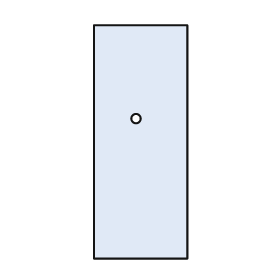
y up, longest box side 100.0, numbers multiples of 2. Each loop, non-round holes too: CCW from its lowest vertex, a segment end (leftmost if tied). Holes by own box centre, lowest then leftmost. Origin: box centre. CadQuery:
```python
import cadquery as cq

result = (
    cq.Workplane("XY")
    .moveTo(-20.0, -50.0)
    .lineTo(20.0, -50.0)
    .lineTo(20.0, 50.0)
    .lineTo(-20.0, 50.0)
    .close()
    .moveTo(-2.0, 10.0)
    .circle(2.0)
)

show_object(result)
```